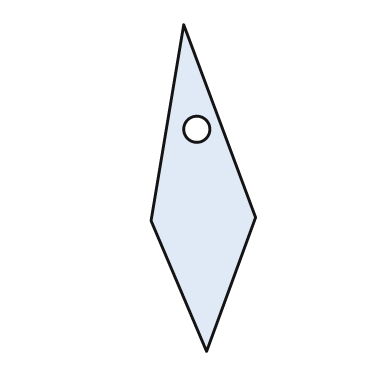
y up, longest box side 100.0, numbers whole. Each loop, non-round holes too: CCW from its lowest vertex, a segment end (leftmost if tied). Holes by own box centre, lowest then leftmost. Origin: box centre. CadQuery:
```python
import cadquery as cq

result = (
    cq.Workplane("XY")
    .moveTo(1.0, -50.0)
    .lineTo(16.0, -9.0)
    .lineTo(-6.0, 50.0)
    .lineTo(-16.0, -10.0)
    .close()
    .moveTo(-2.0, 18.0)
    .circle(4.0)
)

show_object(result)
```